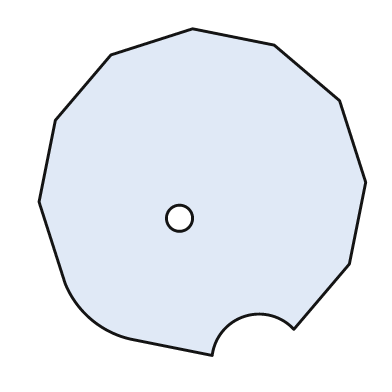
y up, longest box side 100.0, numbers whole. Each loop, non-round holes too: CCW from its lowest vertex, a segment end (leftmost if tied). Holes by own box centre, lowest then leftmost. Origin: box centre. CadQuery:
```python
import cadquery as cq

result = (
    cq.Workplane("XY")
    .moveTo(3.0, -50.0)
    .threePointArc((13.0, -38.0), (28.0, -42.0))
    .lineTo(45.0, -22.0)
    .lineTo(50.0, 3.0)
    .lineTo(42.0, 28.0)
    .lineTo(22.0, 45.0)
    .lineTo(-3.0, 50.0)
    .lineTo(-28.0, 42.0)
    .lineTo(-45.0, 22.0)
    .lineTo(-50.0, -3.0)
    .lineTo(-42.0, -28.0)
    .threePointArc((-34.0, -39.0), (-22.0, -45.0))
    .close()
    .moveTo(-7.0, -8.0)
    .circle(4.0)
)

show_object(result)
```